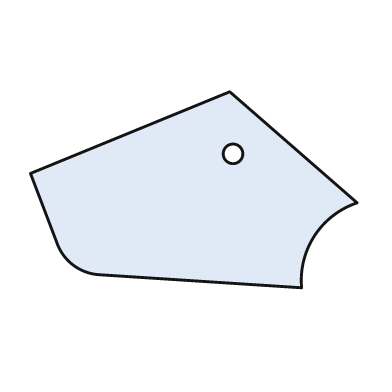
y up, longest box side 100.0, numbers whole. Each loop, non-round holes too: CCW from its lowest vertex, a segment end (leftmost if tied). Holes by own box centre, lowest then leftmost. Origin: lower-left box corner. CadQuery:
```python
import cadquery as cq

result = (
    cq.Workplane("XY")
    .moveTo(83.0, 0.0)
    .threePointArc((87.0, 16.0), (100.0, 26.0))
    .lineTo(61.0, 60.0)
    .lineTo(0.0, 35.0)
    .lineTo(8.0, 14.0)
    .threePointArc((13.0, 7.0), (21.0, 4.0))
    .close()
    .moveTo(62.0, 41.0)
    .circle(3.0)
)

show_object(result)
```